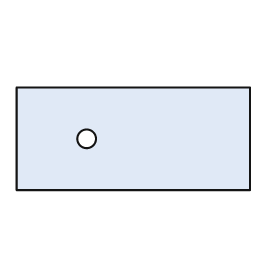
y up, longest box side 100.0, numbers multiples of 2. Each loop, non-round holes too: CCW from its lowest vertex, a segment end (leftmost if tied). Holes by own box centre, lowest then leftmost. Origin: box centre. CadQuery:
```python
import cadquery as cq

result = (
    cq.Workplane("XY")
    .moveTo(-50.0, -22.0)
    .lineTo(50.0, -22.0)
    .lineTo(50.0, 22.0)
    .lineTo(-50.0, 22.0)
    .close()
    .moveTo(-20.0, 0.0)
    .circle(4.0)
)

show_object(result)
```